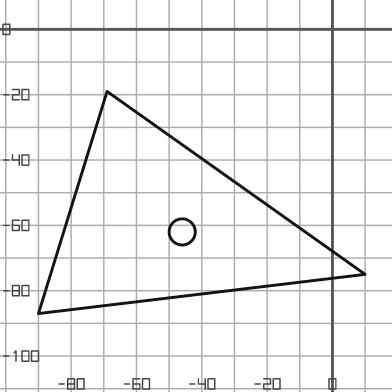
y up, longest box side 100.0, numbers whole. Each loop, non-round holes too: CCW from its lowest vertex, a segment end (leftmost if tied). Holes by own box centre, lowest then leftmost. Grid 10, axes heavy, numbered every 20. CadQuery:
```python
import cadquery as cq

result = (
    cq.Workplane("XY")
    .moveTo(-90.0, -87.0)
    .lineTo(10.0, -75.0)
    .lineTo(-69.0, -19.0)
    .close()
    .moveTo(-46.0, -62.0)
    .circle(4.0)
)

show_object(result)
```